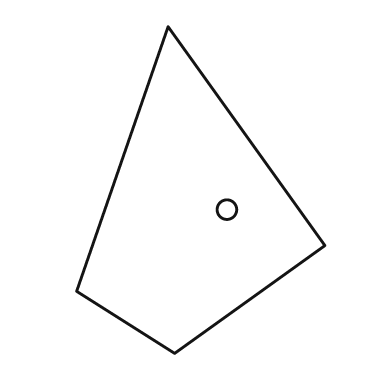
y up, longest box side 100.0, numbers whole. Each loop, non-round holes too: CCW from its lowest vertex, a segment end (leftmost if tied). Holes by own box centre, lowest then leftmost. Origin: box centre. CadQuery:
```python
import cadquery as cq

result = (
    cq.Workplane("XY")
    .moveTo(-8.0, -50.0)
    .lineTo(38.0, -17.0)
    .lineTo(-10.0, 50.0)
    .lineTo(-38.0, -31.0)
    .close()
    .moveTo(8.0, -6.0)
    .circle(3.0)
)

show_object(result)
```